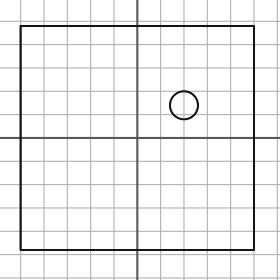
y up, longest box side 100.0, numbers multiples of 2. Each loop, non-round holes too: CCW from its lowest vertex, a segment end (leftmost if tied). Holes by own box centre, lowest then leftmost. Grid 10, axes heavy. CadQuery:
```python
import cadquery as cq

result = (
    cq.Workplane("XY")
    .moveTo(-50.0, -48.0)
    .lineTo(50.0, -48.0)
    .lineTo(50.0, 48.0)
    .lineTo(-50.0, 48.0)
    .close()
    .moveTo(20.0, 14.0)
    .circle(6.0)
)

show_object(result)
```